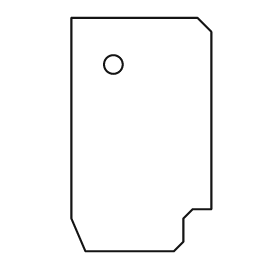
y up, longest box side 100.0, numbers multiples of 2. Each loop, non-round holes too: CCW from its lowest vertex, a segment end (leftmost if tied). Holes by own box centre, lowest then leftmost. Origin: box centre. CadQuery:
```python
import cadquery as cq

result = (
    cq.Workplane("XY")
    .moveTo(-24.0, -50.0)
    .lineTo(14.0, -50.0)
    .lineTo(18.0, -46.0)
    .lineTo(18.0, -36.0)
    .lineTo(22.0, -32.0)
    .lineTo(30.0, -32.0)
    .lineTo(30.0, 44.0)
    .lineTo(24.0, 50.0)
    .lineTo(-30.0, 50.0)
    .lineTo(-30.0, -36.0)
    .close()
    .moveTo(-12.0, 30.0)
    .circle(4.0)
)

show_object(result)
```